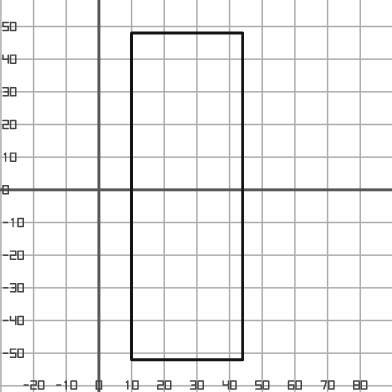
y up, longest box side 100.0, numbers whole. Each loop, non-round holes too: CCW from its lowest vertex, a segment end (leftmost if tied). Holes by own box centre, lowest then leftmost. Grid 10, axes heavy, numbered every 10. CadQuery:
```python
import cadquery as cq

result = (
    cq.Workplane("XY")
    .moveTo(10.0, -52.0)
    .lineTo(44.0, -52.0)
    .lineTo(44.0, 48.0)
    .lineTo(10.0, 48.0)
    .close()
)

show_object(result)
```